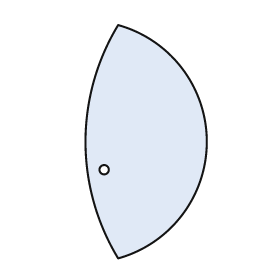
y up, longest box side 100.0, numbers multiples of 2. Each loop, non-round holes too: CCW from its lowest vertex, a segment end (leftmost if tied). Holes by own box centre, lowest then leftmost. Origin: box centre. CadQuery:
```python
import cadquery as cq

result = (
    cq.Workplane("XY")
    .moveTo(-12.0, -50.0)
    .threePointArc((26.0, 0.0), (-12.0, 50.0))
    .threePointArc((-26.0, 0.0), (-12.0, -50.0))
    .close()
    .moveTo(-18.0, -12.0)
    .circle(2.0)
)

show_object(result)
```